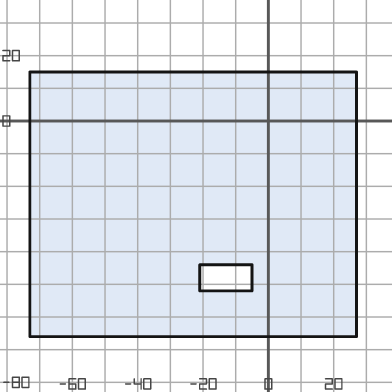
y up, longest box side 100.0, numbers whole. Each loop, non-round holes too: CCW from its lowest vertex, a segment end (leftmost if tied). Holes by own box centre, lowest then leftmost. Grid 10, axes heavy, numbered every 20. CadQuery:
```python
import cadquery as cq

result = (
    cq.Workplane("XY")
    .moveTo(-73.0, -66.0)
    .lineTo(27.0, -66.0)
    .lineTo(27.0, 15.0)
    .lineTo(-73.0, 15.0)
    .close()
    .moveTo(-21.0, -52.0)
    .lineTo(-5.0, -52.0)
    .lineTo(-5.0, -44.0)
    .lineTo(-21.0, -44.0)
    .close()
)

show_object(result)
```